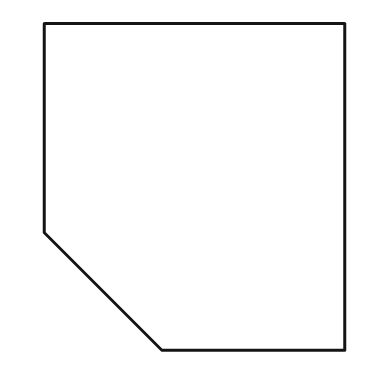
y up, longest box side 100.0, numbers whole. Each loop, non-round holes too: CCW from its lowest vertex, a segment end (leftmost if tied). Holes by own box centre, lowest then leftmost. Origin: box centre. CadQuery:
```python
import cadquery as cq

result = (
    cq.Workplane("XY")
    .moveTo(-10.0, -50.0)
    .lineTo(46.0, -50.0)
    .lineTo(46.0, 50.0)
    .lineTo(-46.0, 50.0)
    .lineTo(-46.0, -14.0)
    .close()
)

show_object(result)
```